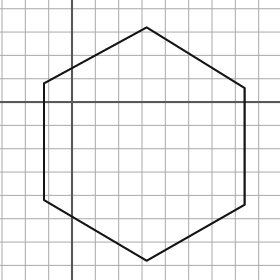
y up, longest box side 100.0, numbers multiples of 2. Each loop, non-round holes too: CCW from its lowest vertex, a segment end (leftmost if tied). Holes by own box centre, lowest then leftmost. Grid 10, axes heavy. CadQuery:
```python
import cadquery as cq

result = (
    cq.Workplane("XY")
    .moveTo(32.0, -68.0)
    .lineTo(74.0, -44.0)
    .lineTo(74.0, 6.0)
    .lineTo(32.0, 32.0)
    .lineTo(-12.0, 8.0)
    .lineTo(-12.0, -42.0)
    .close()
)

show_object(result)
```